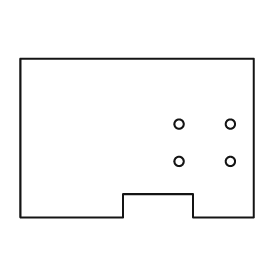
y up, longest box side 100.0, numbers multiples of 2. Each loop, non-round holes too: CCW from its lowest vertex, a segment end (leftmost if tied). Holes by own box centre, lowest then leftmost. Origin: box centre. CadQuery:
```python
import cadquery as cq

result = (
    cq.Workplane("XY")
    .moveTo(-50.0, -34.0)
    .lineTo(-6.0, -34.0)
    .lineTo(-6.0, -24.0)
    .lineTo(24.0, -24.0)
    .lineTo(24.0, -34.0)
    .lineTo(50.0, -34.0)
    .lineTo(50.0, 34.0)
    .lineTo(-50.0, 34.0)
    .close()
    .moveTo(18.0, -10.0)
    .circle(2.0)
    .moveTo(40.0, -10.0)
    .circle(2.0)
    .moveTo(18.0, 6.0)
    .circle(2.0)
    .moveTo(40.0, 6.0)
    .circle(2.0)
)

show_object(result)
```